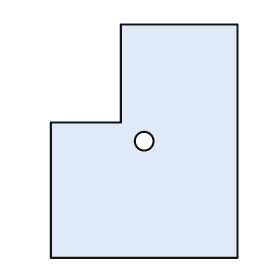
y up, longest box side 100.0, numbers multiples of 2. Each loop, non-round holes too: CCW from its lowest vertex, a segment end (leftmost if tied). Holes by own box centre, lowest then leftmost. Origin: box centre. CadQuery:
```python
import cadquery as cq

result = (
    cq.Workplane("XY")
    .moveTo(-40.0, -50.0)
    .lineTo(40.0, -50.0)
    .lineTo(40.0, 50.0)
    .lineTo(-10.0, 50.0)
    .lineTo(-10.0, 8.0)
    .lineTo(-40.0, 8.0)
    .close()
    .moveTo(0.0, 0.0)
    .circle(4.0)
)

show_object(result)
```